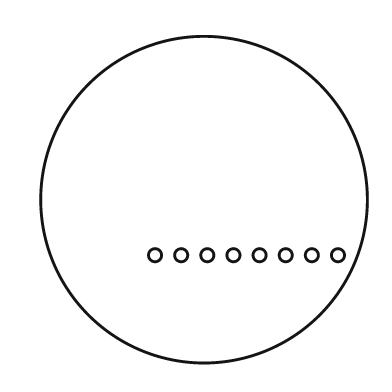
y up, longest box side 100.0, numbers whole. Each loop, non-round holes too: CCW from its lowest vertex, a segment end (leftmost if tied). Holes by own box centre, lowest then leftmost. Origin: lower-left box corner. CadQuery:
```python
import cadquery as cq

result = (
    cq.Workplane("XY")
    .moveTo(50.0, 50.0)
    .circle(50.0)
    .moveTo(35.0, 33.0)
    .circle(2.0)
    .moveTo(43.0, 33.0)
    .circle(2.0)
    .moveTo(51.0, 33.0)
    .circle(2.0)
    .moveTo(59.0, 33.0)
    .circle(2.0)
    .moveTo(67.0, 33.0)
    .circle(2.0)
    .moveTo(75.0, 33.0)
    .circle(2.0)
    .moveTo(83.0, 33.0)
    .circle(2.0)
    .moveTo(91.0, 33.0)
    .circle(2.0)
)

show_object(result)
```